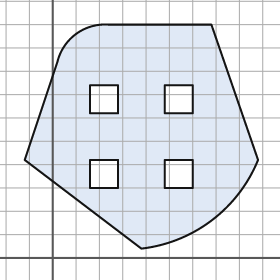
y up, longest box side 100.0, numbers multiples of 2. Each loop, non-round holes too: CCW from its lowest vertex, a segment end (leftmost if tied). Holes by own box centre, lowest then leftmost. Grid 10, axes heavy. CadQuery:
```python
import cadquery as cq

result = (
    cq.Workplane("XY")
    .moveTo(38.0, 4.0)
    .threePointArc((68.0, 16.0), (88.0, 42.0))
    .lineTo(68.0, 100.0)
    .lineTo(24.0, 100.0)
    .threePointArc((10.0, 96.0), (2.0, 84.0))
    .lineTo(-12.0, 42.0)
    .close()
    .moveTo(16.0, 30.0)
    .lineTo(28.0, 30.0)
    .lineTo(28.0, 42.0)
    .lineTo(16.0, 42.0)
    .close()
    .moveTo(48.0, 30.0)
    .lineTo(60.0, 30.0)
    .lineTo(60.0, 42.0)
    .lineTo(48.0, 42.0)
    .close()
    .moveTo(16.0, 62.0)
    .lineTo(28.0, 62.0)
    .lineTo(28.0, 74.0)
    .lineTo(16.0, 74.0)
    .close()
    .moveTo(48.0, 62.0)
    .lineTo(60.0, 62.0)
    .lineTo(60.0, 74.0)
    .lineTo(48.0, 74.0)
    .close()
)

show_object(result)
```